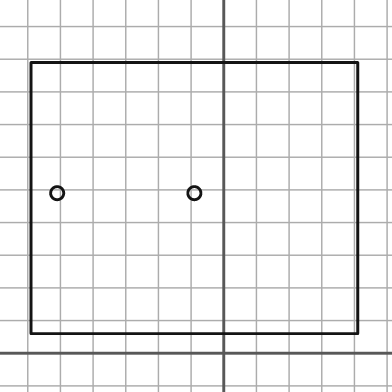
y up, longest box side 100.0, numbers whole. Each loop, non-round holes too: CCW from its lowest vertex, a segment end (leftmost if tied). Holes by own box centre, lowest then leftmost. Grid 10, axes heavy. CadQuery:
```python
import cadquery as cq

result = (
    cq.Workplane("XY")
    .moveTo(-59.0, 6.0)
    .lineTo(41.0, 6.0)
    .lineTo(41.0, 89.0)
    .lineTo(-59.0, 89.0)
    .close()
    .moveTo(-51.0, 49.0)
    .circle(2.0)
    .moveTo(-9.0, 49.0)
    .circle(2.0)
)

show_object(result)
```